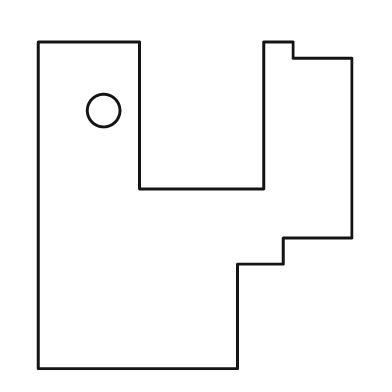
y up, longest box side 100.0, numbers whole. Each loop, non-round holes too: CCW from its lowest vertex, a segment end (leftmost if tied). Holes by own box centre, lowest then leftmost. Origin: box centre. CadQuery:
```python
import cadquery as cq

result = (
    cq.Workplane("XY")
    .moveTo(-48.0, -50.0)
    .lineTo(13.0, -50.0)
    .lineTo(13.0, -18.0)
    .lineTo(27.0, -18.0)
    .lineTo(27.0, -10.0)
    .lineTo(48.0, -10.0)
    .lineTo(48.0, 45.0)
    .lineTo(30.0, 45.0)
    .lineTo(30.0, 50.0)
    .lineTo(21.0, 50.0)
    .lineTo(21.0, 5.0)
    .lineTo(-17.0, 5.0)
    .lineTo(-17.0, 50.0)
    .lineTo(-48.0, 50.0)
    .close()
    .moveTo(-28.0, 29.0)
    .circle(5.0)
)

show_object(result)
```